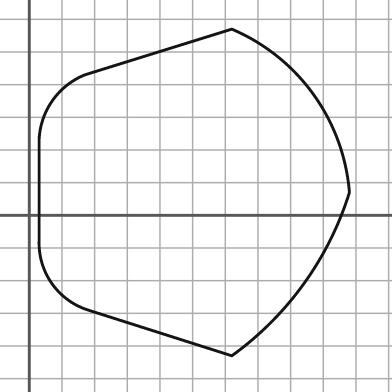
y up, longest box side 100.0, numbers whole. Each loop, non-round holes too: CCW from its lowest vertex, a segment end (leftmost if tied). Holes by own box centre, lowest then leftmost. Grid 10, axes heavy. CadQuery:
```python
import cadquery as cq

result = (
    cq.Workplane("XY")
    .moveTo(62.0, -43.0)
    .threePointArc((84.0, -21.0), (98.0, 7.0))
    .threePointArc((87.0, 37.0), (62.0, 57.0))
    .lineTo(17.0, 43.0)
    .threePointArc((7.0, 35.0), (3.0, 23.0))
    .lineTo(3.0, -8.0)
    .threePointArc((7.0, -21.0), (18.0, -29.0))
    .close()
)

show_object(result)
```